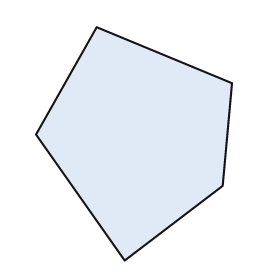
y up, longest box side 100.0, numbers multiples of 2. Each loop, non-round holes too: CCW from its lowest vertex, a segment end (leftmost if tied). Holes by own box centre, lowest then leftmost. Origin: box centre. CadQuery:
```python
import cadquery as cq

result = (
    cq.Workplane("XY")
    .moveTo(-4.0, -50.0)
    .lineTo(38.0, -18.0)
    .lineTo(42.0, 26.0)
    .lineTo(-16.0, 50.0)
    .lineTo(-42.0, 4.0)
    .close()
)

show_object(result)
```